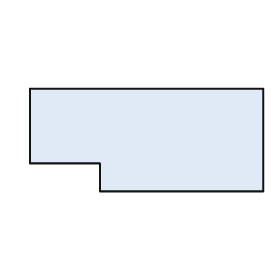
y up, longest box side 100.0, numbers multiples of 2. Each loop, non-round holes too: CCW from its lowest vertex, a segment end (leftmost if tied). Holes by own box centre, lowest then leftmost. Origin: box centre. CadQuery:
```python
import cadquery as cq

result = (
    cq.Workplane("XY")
    .moveTo(-20.0, -22.0)
    .lineTo(50.0, -22.0)
    .lineTo(50.0, 22.0)
    .lineTo(-50.0, 22.0)
    .lineTo(-50.0, -10.0)
    .lineTo(-20.0, -10.0)
    .close()
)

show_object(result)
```